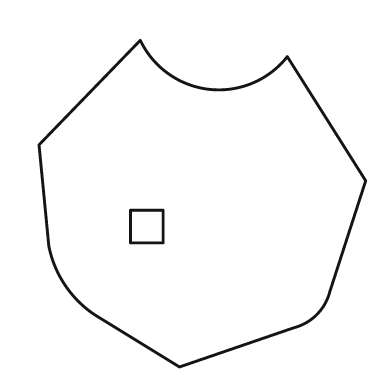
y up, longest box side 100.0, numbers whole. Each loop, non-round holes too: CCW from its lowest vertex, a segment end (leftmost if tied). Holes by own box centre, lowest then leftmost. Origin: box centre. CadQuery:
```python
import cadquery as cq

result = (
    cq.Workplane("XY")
    .moveTo(-7.0, -50.0)
    .lineTo(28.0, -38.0)
    .threePointArc((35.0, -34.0), (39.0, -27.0))
    .lineTo(50.0, 7.0)
    .lineTo(26.0, 45.0)
    .threePointArc((2.0, 35.0), (-19.0, 50.0))
    .lineTo(-50.0, 18.0)
    .lineTo(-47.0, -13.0)
    .threePointArc((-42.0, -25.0), (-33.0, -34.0))
    .close()
    .moveTo(-22.0, -12.0)
    .lineTo(-12.0, -12.0)
    .lineTo(-12.0, -2.0)
    .lineTo(-22.0, -2.0)
    .close()
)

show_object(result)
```